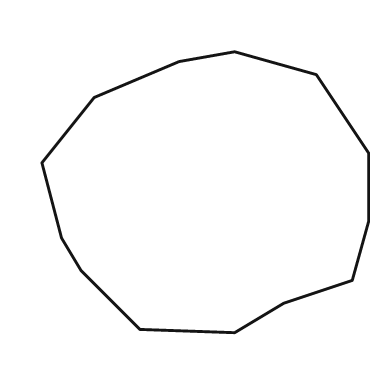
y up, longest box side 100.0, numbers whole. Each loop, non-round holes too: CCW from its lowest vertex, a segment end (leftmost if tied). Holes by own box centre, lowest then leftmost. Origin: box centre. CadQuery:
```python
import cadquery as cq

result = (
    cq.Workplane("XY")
    .moveTo(9.0, -43.0)
    .lineTo(24.0, -34.0)
    .lineTo(45.0, -27.0)
    .lineTo(50.0, -9.0)
    .lineTo(50.0, 12.0)
    .lineTo(34.0, 36.0)
    .lineTo(9.0, 43.0)
    .lineTo(-8.0, 40.0)
    .lineTo(-34.0, 29.0)
    .lineTo(-50.0, 9.0)
    .lineTo(-44.0, -14.0)
    .lineTo(-38.0, -24.0)
    .lineTo(-20.0, -42.0)
    .close()
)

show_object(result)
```